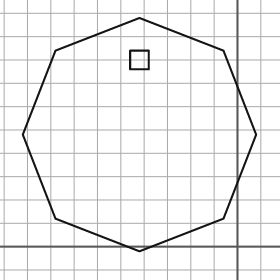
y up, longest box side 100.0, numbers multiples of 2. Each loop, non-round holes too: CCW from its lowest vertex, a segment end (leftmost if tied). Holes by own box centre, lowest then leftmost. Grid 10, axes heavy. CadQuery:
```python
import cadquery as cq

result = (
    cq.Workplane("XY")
    .moveTo(-42.0, -2.0)
    .lineTo(-6.0, 12.0)
    .lineTo(8.0, 48.0)
    .lineTo(-6.0, 84.0)
    .lineTo(-42.0, 98.0)
    .lineTo(-78.0, 84.0)
    .lineTo(-92.0, 48.0)
    .lineTo(-78.0, 12.0)
    .close()
    .moveTo(-46.0, 76.0)
    .lineTo(-38.0, 76.0)
    .lineTo(-38.0, 84.0)
    .lineTo(-46.0, 84.0)
    .close()
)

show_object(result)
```